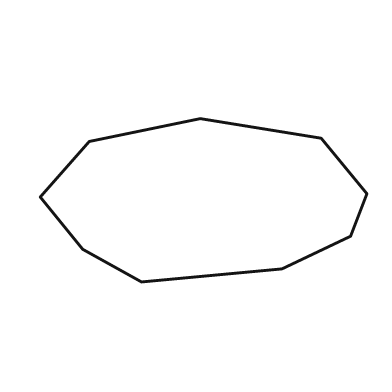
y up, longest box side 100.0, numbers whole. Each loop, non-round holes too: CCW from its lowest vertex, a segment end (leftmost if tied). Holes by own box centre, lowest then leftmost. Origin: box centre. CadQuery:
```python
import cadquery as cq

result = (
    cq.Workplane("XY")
    .moveTo(-19.0, -25.0)
    .lineTo(24.0, -21.0)
    .lineTo(45.0, -11.0)
    .lineTo(50.0, 2.0)
    .lineTo(36.0, 19.0)
    .lineTo(-1.0, 25.0)
    .lineTo(-35.0, 18.0)
    .lineTo(-50.0, 1.0)
    .lineTo(-37.0, -15.0)
    .close()
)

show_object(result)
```